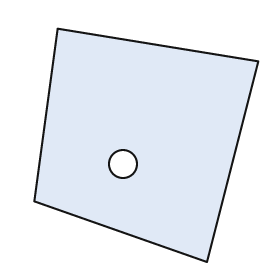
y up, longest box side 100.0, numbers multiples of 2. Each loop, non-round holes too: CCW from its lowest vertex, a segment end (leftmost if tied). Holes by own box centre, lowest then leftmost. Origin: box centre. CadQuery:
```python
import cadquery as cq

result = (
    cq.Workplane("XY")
    .moveTo(26.0, -50.0)
    .lineTo(48.0, 36.0)
    .lineTo(-38.0, 50.0)
    .lineTo(-48.0, -24.0)
    .close()
    .moveTo(-10.0, -8.0)
    .circle(6.0)
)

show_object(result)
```